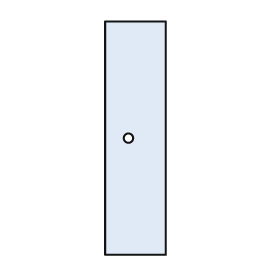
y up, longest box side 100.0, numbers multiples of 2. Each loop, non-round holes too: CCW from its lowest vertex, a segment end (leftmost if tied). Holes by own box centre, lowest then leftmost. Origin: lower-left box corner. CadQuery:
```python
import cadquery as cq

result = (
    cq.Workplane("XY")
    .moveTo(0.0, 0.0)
    .lineTo(26.0, 0.0)
    .lineTo(26.0, 100.0)
    .lineTo(0.0, 100.0)
    .close()
    .moveTo(10.0, 50.0)
    .circle(2.0)
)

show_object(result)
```